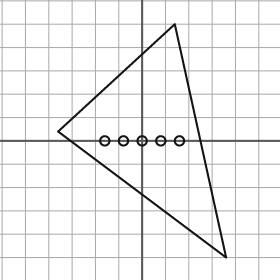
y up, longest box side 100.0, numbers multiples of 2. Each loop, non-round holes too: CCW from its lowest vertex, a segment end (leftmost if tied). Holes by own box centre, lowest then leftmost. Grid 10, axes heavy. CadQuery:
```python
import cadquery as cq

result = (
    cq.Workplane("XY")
    .moveTo(36.0, -50.0)
    .lineTo(14.0, 50.0)
    .lineTo(-36.0, 4.0)
    .close()
    .moveTo(-16.0, 0.0)
    .circle(2.0)
    .moveTo(-8.0, 0.0)
    .circle(2.0)
    .moveTo(0.0, 0.0)
    .circle(2.0)
    .moveTo(8.0, 0.0)
    .circle(2.0)
    .moveTo(16.0, 0.0)
    .circle(2.0)
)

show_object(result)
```